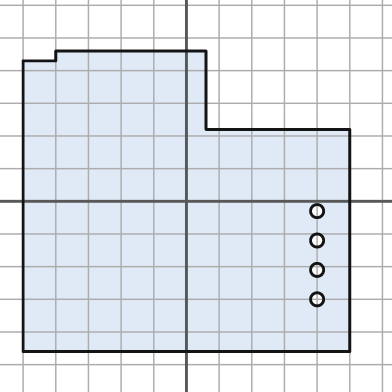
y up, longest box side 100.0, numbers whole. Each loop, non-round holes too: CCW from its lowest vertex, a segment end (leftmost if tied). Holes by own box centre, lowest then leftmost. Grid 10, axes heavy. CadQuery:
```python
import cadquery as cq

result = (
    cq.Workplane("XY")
    .moveTo(-50.0, -46.0)
    .lineTo(50.0, -46.0)
    .lineTo(50.0, 22.0)
    .lineTo(6.0, 22.0)
    .lineTo(6.0, 46.0)
    .lineTo(-40.0, 46.0)
    .lineTo(-40.0, 43.0)
    .lineTo(-50.0, 43.0)
    .close()
    .moveTo(40.0, -30.0)
    .circle(2.0)
    .moveTo(40.0, -21.0)
    .circle(2.0)
    .moveTo(40.0, -12.0)
    .circle(2.0)
    .moveTo(40.0, -3.0)
    .circle(2.0)
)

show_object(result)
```